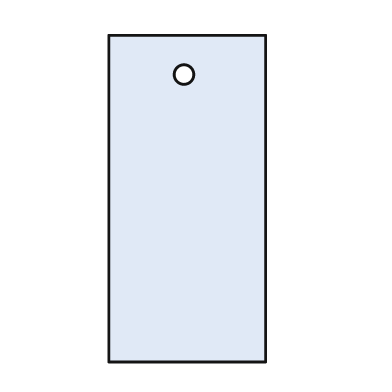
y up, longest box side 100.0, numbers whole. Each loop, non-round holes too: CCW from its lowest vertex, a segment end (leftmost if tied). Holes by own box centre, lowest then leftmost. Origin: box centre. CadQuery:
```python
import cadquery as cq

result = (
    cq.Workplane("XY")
    .moveTo(-24.0, -50.0)
    .lineTo(24.0, -50.0)
    .lineTo(24.0, 50.0)
    .lineTo(-24.0, 50.0)
    .close()
    .moveTo(-1.0, 38.0)
    .circle(3.0)
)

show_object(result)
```